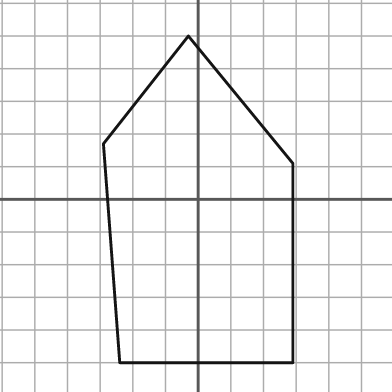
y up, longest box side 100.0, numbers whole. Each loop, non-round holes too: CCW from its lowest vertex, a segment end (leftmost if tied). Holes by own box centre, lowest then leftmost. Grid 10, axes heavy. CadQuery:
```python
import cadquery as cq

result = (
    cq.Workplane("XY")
    .moveTo(-24.0, -50.0)
    .lineTo(29.0, -50.0)
    .lineTo(29.0, 11.0)
    .lineTo(-3.0, 50.0)
    .lineTo(-29.0, 17.0)
    .close()
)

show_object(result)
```